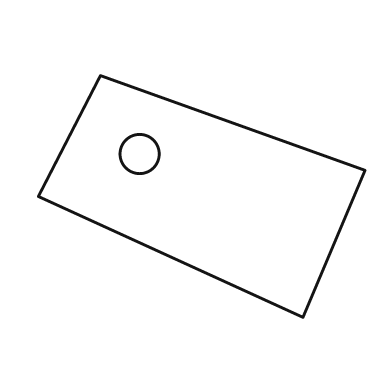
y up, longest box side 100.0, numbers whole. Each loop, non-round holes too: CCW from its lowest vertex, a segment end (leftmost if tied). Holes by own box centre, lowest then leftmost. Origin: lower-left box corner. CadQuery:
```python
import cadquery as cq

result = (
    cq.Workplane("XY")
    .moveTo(81.0, 0.0)
    .lineTo(100.0, 45.0)
    .lineTo(19.0, 74.0)
    .lineTo(0.0, 37.0)
    .close()
    .moveTo(31.0, 50.0)
    .circle(6.0)
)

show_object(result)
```